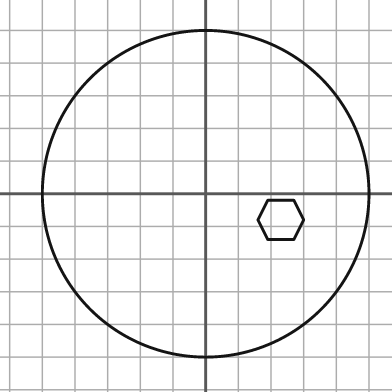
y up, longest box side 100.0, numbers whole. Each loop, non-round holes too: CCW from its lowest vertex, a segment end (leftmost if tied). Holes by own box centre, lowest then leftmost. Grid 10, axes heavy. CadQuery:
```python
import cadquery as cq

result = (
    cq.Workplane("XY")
    .moveTo(0.0, 0.0)
    .circle(50.0)
    .moveTo(19.0, -14.0)
    .lineTo(27.0, -14.0)
    .lineTo(30.0, -8.0)
    .lineTo(27.0, -2.0)
    .lineTo(19.0, -2.0)
    .lineTo(16.0, -8.0)
    .close()
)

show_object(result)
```